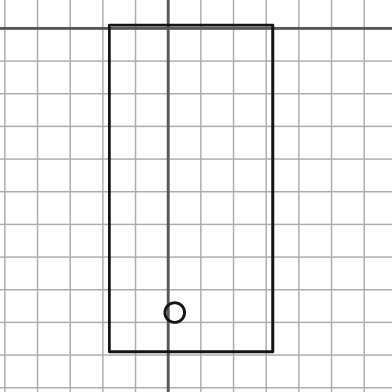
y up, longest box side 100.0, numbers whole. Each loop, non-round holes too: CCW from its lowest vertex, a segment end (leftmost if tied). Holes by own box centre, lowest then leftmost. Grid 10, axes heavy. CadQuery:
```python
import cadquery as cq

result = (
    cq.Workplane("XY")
    .moveTo(-18.0, -99.0)
    .lineTo(32.0, -99.0)
    .lineTo(32.0, 1.0)
    .lineTo(-18.0, 1.0)
    .close()
    .moveTo(2.0, -87.0)
    .circle(3.0)
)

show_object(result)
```